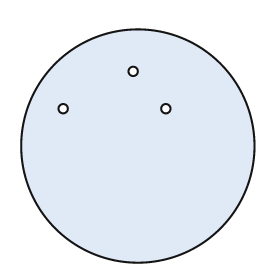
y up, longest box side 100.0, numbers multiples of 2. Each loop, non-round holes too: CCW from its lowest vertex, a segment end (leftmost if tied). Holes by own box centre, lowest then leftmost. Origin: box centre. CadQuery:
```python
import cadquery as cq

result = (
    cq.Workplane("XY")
    .moveTo(0.0, 0.0)
    .circle(50.0)
    .moveTo(-32.0, 16.0)
    .circle(2.0)
    .moveTo(12.0, 16.0)
    .circle(2.0)
    .moveTo(-2.0, 32.0)
    .circle(2.0)
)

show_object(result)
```